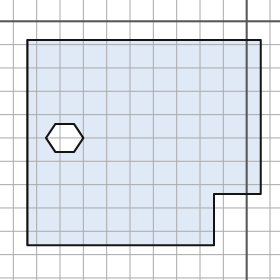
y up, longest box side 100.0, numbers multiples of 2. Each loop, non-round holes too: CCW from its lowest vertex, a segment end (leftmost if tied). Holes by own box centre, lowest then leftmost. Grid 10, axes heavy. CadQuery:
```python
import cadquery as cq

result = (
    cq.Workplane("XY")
    .moveTo(-94.0, -96.0)
    .lineTo(-14.0, -96.0)
    .lineTo(-14.0, -74.0)
    .lineTo(6.0, -74.0)
    .lineTo(6.0, -8.0)
    .lineTo(-94.0, -8.0)
    .close()
    .moveTo(-82.0, -56.0)
    .lineTo(-74.0, -56.0)
    .lineTo(-70.0, -50.0)
    .lineTo(-74.0, -44.0)
    .lineTo(-82.0, -44.0)
    .lineTo(-86.0, -50.0)
    .close()
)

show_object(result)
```